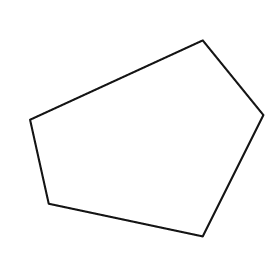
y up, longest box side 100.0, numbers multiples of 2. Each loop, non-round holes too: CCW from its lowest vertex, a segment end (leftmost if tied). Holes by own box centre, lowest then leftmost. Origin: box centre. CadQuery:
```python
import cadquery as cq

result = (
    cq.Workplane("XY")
    .moveTo(24.0, -42.0)
    .lineTo(50.0, 10.0)
    .lineTo(24.0, 42.0)
    .lineTo(-50.0, 8.0)
    .lineTo(-42.0, -28.0)
    .close()
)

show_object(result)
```